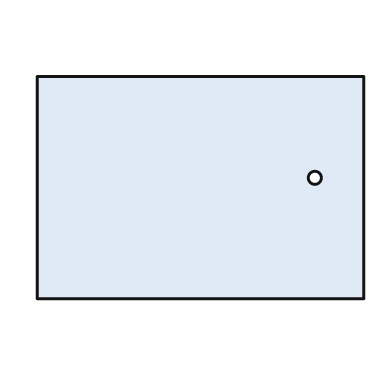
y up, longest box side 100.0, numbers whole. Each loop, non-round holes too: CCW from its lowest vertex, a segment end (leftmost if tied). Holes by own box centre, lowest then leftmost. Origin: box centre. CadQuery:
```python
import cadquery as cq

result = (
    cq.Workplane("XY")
    .moveTo(-50.0, -34.0)
    .lineTo(50.0, -34.0)
    .lineTo(50.0, 34.0)
    .lineTo(-50.0, 34.0)
    .close()
    .moveTo(35.0, 3.0)
    .circle(2.0)
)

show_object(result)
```